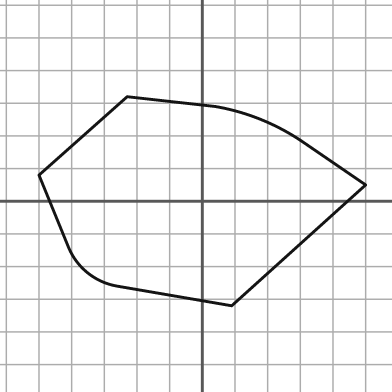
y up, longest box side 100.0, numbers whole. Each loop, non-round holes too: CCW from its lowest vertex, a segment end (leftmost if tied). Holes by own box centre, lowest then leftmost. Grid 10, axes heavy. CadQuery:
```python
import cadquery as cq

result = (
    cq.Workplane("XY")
    .moveTo(9.0, -32.0)
    .lineTo(50.0, 5.0)
    .lineTo(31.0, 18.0)
    .threePointArc((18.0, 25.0), (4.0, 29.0))
    .lineTo(-23.0, 32.0)
    .lineTo(-50.0, 8.0)
    .lineTo(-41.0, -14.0)
    .threePointArc((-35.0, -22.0), (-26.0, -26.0))
    .close()
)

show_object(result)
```